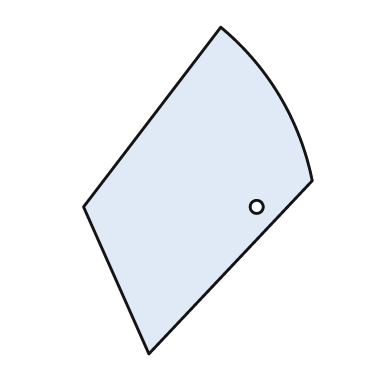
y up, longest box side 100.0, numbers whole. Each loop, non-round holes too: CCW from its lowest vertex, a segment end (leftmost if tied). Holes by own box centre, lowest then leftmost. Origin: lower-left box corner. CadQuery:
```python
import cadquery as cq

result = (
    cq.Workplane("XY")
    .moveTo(20.0, 0.0)
    .lineTo(70.0, 53.0)
    .threePointArc((60.0, 79.0), (42.0, 100.0))
    .lineTo(0.0, 45.0)
    .close()
    .moveTo(53.0, 45.0)
    .circle(2.0)
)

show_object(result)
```